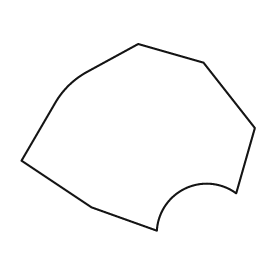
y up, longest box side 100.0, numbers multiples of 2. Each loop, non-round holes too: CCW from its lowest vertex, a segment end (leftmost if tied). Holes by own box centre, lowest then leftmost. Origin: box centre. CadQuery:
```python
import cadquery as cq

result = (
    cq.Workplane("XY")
    .moveTo(8.0, -40.0)
    .threePointArc((20.0, -22.0), (42.0, -24.0))
    .lineTo(50.0, 4.0)
    .lineTo(28.0, 32.0)
    .lineTo(0.0, 40.0)
    .lineTo(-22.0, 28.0)
    .threePointArc((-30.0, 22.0), (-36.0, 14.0))
    .lineTo(-50.0, -10.0)
    .lineTo(-20.0, -30.0)
    .close()
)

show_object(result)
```